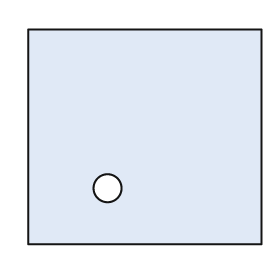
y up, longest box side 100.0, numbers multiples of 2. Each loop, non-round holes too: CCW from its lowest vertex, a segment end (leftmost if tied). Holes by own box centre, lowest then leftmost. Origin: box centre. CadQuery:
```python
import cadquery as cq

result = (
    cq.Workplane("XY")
    .moveTo(-50.0, -46.0)
    .lineTo(50.0, -46.0)
    .lineTo(50.0, 46.0)
    .lineTo(-50.0, 46.0)
    .close()
    .moveTo(-16.0, -22.0)
    .circle(6.0)
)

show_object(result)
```